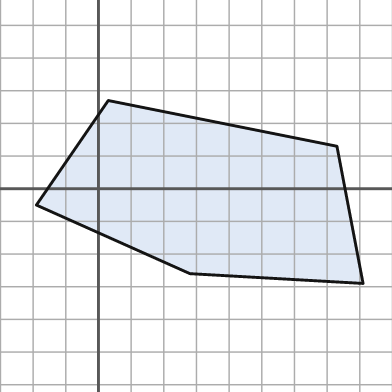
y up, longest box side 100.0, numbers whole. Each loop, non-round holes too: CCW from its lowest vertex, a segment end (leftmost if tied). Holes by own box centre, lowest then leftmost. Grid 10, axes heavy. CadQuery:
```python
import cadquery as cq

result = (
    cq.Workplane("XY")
    .moveTo(81.0, -29.0)
    .lineTo(73.0, 13.0)
    .lineTo(3.0, 27.0)
    .lineTo(-19.0, -5.0)
    .lineTo(28.0, -26.0)
    .close()
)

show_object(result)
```